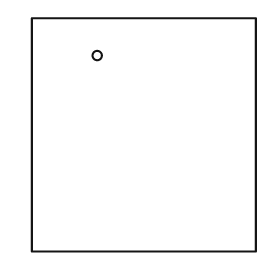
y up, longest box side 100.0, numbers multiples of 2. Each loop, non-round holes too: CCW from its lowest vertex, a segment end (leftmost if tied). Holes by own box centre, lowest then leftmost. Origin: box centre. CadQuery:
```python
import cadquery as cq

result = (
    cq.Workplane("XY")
    .moveTo(-48.0, -50.0)
    .lineTo(48.0, -50.0)
    .lineTo(48.0, 50.0)
    .lineTo(-48.0, 50.0)
    .close()
    .moveTo(-20.0, 34.0)
    .circle(2.0)
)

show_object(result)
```